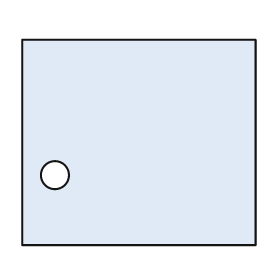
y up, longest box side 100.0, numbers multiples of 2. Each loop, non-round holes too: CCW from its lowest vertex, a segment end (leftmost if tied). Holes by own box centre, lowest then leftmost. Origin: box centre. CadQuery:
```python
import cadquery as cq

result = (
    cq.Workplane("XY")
    .moveTo(-50.0, -44.0)
    .lineTo(50.0, -44.0)
    .lineTo(50.0, 44.0)
    .lineTo(-50.0, 44.0)
    .close()
    .moveTo(-36.0, -14.0)
    .circle(6.0)
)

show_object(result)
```